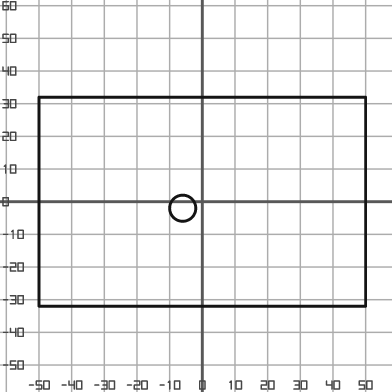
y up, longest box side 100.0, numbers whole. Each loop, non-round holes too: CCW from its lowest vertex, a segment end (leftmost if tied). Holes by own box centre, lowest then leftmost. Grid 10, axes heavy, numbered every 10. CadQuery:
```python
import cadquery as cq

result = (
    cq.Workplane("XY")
    .moveTo(-50.0, -32.0)
    .lineTo(50.0, -32.0)
    .lineTo(50.0, 32.0)
    .lineTo(-50.0, 32.0)
    .close()
    .moveTo(-6.0, -2.0)
    .circle(4.0)
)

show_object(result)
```